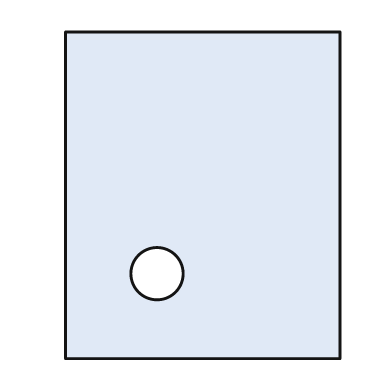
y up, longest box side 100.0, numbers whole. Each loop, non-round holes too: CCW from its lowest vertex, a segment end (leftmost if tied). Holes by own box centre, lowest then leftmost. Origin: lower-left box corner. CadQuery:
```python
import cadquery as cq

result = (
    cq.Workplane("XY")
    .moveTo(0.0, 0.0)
    .lineTo(84.0, 0.0)
    .lineTo(84.0, 100.0)
    .lineTo(0.0, 100.0)
    .close()
    .moveTo(28.0, 26.0)
    .circle(8.0)
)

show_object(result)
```